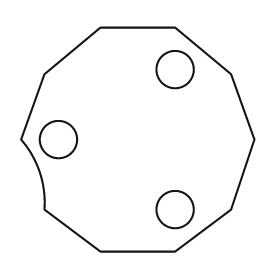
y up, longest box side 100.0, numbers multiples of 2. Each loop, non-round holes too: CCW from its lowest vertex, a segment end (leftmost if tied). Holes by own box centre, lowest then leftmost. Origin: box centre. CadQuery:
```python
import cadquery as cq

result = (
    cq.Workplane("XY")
    .moveTo(-16.0, -48.0)
    .lineTo(16.0, -48.0)
    .lineTo(40.0, -30.0)
    .lineTo(50.0, 0.0)
    .lineTo(40.0, 28.0)
    .lineTo(16.0, 48.0)
    .lineTo(-16.0, 48.0)
    .lineTo(-40.0, 28.0)
    .lineTo(-50.0, 0.0)
    .threePointArc((-42.0, -14.0), (-40.0, -30.0))
    .close()
    .moveTo(16.0, -30.0)
    .circle(8.0)
    .moveTo(-34.0, 0.0)
    .circle(8.0)
    .moveTo(16.0, 30.0)
    .circle(8.0)
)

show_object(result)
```